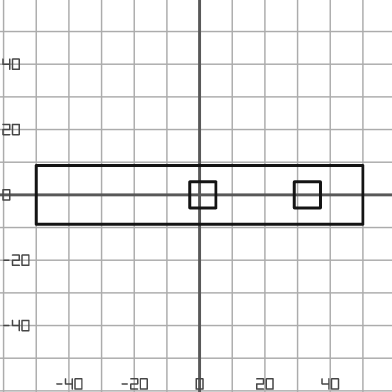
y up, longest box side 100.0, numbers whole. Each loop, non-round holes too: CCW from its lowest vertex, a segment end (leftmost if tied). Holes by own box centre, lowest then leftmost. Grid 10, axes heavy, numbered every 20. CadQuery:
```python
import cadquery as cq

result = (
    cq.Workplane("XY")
    .moveTo(-50.0, -9.0)
    .lineTo(50.0, -9.0)
    .lineTo(50.0, 9.0)
    .lineTo(-50.0, 9.0)
    .close()
    .moveTo(-3.0, -4.0)
    .lineTo(5.0, -4.0)
    .lineTo(5.0, 4.0)
    .lineTo(-3.0, 4.0)
    .close()
    .moveTo(29.0, -4.0)
    .lineTo(37.0, -4.0)
    .lineTo(37.0, 4.0)
    .lineTo(29.0, 4.0)
    .close()
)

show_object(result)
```